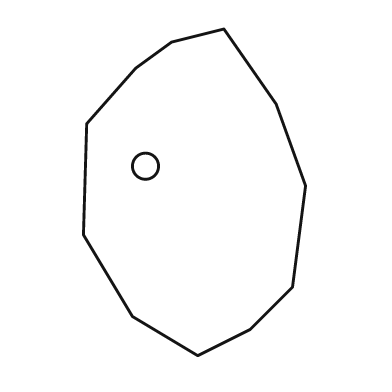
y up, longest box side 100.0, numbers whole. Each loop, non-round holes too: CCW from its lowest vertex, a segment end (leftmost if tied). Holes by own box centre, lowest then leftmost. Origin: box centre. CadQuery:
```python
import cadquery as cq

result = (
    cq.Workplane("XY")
    .moveTo(1.0, -50.0)
    .lineTo(17.0, -42.0)
    .lineTo(30.0, -29.0)
    .lineTo(34.0, 2.0)
    .lineTo(25.0, 27.0)
    .lineTo(9.0, 50.0)
    .lineTo(-7.0, 46.0)
    .lineTo(-18.0, 38.0)
    .lineTo(-33.0, 21.0)
    .lineTo(-34.0, -13.0)
    .lineTo(-19.0, -38.0)
    .close()
    .moveTo(-15.0, 8.0)
    .circle(4.0)
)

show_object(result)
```